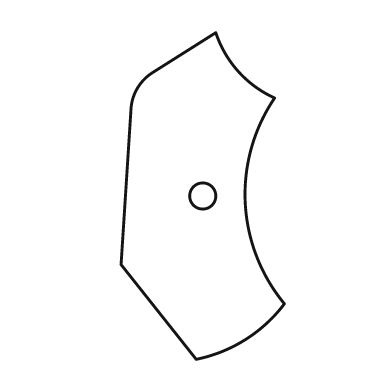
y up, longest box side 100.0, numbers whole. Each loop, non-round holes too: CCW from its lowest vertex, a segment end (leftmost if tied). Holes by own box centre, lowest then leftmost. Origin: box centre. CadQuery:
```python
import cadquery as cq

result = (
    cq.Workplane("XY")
    .moveTo(-2.0, -50.0)
    .threePointArc((13.0, -44.0), (25.0, -33.0))
    .threePointArc((13.0, -2.0), (22.0, 30.0))
    .threePointArc((11.0, 38.0), (4.0, 50.0))
    .lineTo(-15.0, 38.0)
    .threePointArc((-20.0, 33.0), (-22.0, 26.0))
    .lineTo(-25.0, -21.0)
    .close()
    .moveTo(0.0, 0.0)
    .circle(4.0)
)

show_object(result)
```